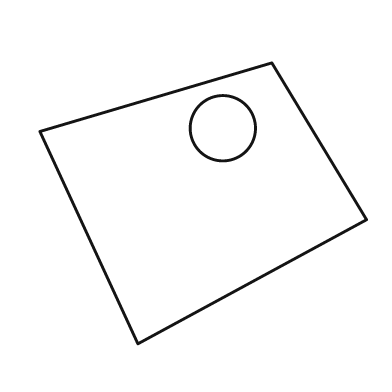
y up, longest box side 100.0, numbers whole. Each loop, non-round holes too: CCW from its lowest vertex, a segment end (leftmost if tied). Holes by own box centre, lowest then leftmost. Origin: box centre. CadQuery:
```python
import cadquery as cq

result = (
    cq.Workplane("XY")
    .moveTo(-20.0, -43.0)
    .lineTo(50.0, -5.0)
    .lineTo(21.0, 43.0)
    .lineTo(-50.0, 22.0)
    .close()
    .moveTo(6.0, 23.0)
    .circle(10.0)
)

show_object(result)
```